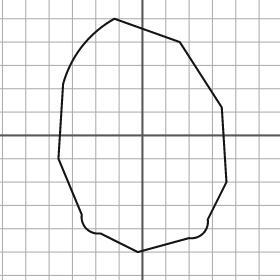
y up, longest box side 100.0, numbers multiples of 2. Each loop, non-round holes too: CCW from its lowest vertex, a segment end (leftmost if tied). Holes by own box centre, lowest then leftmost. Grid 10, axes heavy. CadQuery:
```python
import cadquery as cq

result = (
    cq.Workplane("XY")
    .moveTo(-2.0, -50.0)
    .lineTo(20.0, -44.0)
    .threePointArc((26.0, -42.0), (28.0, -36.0))
    .lineTo(36.0, -20.0)
    .lineTo(34.0, 12.0)
    .lineTo(16.0, 40.0)
    .lineTo(-12.0, 50.0)
    .threePointArc((-26.0, 38.0), (-34.0, 22.0))
    .lineTo(-36.0, -10.0)
    .lineTo(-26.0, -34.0)
    .threePointArc((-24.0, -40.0), (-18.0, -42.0))
    .close()
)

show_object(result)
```